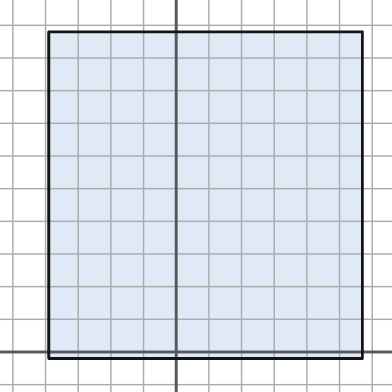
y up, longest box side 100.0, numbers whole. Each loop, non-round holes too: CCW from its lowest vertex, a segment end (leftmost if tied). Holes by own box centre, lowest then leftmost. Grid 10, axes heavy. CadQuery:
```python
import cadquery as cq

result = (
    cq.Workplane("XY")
    .moveTo(-39.0, -2.0)
    .lineTo(57.0, -2.0)
    .lineTo(57.0, 98.0)
    .lineTo(-39.0, 98.0)
    .close()
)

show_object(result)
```